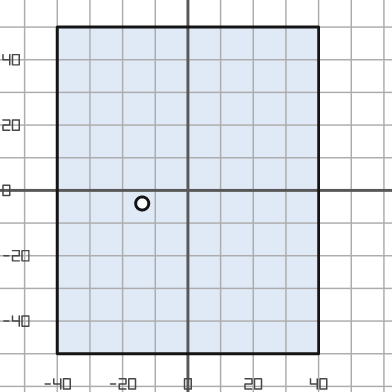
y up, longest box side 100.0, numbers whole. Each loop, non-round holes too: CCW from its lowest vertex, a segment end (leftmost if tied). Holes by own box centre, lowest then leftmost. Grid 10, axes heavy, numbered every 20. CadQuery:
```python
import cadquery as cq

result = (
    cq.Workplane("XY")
    .moveTo(-40.0, -50.0)
    .lineTo(40.0, -50.0)
    .lineTo(40.0, 50.0)
    .lineTo(-40.0, 50.0)
    .close()
    .moveTo(-14.0, -4.0)
    .circle(2.0)
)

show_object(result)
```